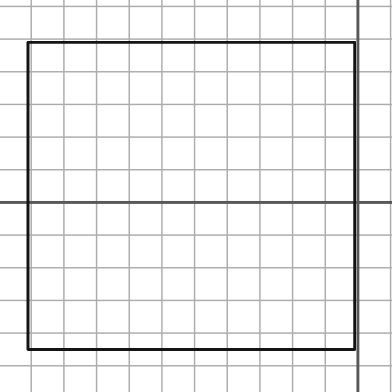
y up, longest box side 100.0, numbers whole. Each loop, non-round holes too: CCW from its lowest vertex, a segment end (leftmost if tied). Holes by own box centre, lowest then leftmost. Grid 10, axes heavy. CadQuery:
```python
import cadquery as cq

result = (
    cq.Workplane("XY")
    .moveTo(-101.0, -45.0)
    .lineTo(-1.0, -45.0)
    .lineTo(-1.0, 49.0)
    .lineTo(-101.0, 49.0)
    .close()
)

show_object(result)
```